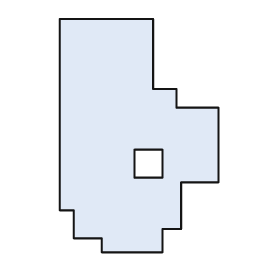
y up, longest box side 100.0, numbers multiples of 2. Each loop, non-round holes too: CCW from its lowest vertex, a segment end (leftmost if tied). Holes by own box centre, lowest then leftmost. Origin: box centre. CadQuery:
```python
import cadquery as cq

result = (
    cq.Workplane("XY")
    .moveTo(-16.0, -50.0)
    .lineTo(10.0, -50.0)
    .lineTo(10.0, -40.0)
    .lineTo(18.0, -40.0)
    .lineTo(18.0, -20.0)
    .lineTo(34.0, -20.0)
    .lineTo(34.0, 12.0)
    .lineTo(16.0, 12.0)
    .lineTo(16.0, 20.0)
    .lineTo(6.0, 20.0)
    .lineTo(6.0, 50.0)
    .lineTo(-34.0, 50.0)
    .lineTo(-34.0, -32.0)
    .lineTo(-28.0, -32.0)
    .lineTo(-28.0, -44.0)
    .lineTo(-16.0, -44.0)
    .close()
    .moveTo(-2.0, -18.0)
    .lineTo(10.0, -18.0)
    .lineTo(10.0, -6.0)
    .lineTo(-2.0, -6.0)
    .close()
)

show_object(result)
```